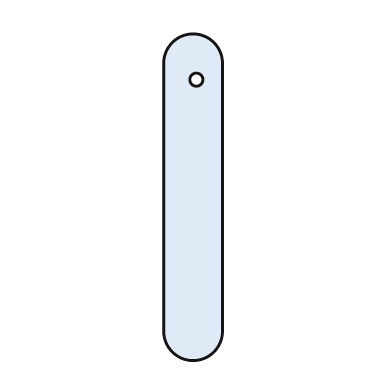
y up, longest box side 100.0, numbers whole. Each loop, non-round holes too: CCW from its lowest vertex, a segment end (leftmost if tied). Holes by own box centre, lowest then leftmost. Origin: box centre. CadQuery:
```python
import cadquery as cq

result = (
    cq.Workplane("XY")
    .moveTo(-9.0, -41.0)
    .threePointArc((0.0, -50.0), (9.0, -41.0))
    .lineTo(9.0, 41.0)
    .threePointArc((0.0, 50.0), (-9.0, 41.0))
    .close()
    .moveTo(1.0, 36.0)
    .circle(2.0)
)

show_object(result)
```